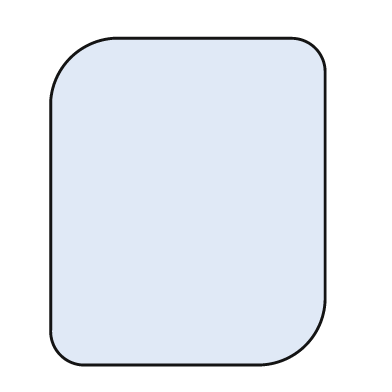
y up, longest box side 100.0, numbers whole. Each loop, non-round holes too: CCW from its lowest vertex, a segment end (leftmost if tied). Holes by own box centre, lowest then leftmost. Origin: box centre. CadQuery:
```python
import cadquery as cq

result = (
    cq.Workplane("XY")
    .moveTo(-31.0, -50.0)
    .lineTo(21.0, -50.0)
    .threePointArc((36.0, -44.0), (42.0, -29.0))
    .lineTo(42.0, 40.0)
    .threePointArc((39.0, 47.0), (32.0, 50.0))
    .lineTo(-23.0, 50.0)
    .threePointArc((-36.0, 44.0), (-42.0, 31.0))
    .lineTo(-42.0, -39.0)
    .threePointArc((-39.0, -47.0), (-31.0, -50.0))
    .close()
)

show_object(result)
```